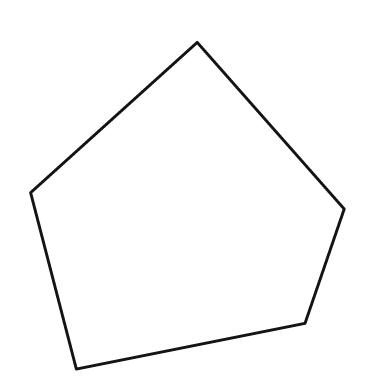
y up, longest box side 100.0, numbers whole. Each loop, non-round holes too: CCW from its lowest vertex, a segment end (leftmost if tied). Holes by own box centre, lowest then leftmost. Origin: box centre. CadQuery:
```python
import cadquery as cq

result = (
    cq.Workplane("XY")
    .moveTo(-34.0, -50.0)
    .lineTo(36.0, -36.0)
    .lineTo(48.0, -1.0)
    .lineTo(3.0, 50.0)
    .lineTo(-48.0, 4.0)
    .close()
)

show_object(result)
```